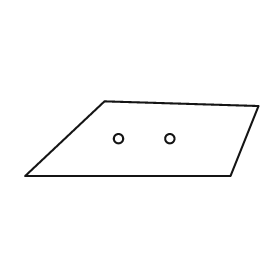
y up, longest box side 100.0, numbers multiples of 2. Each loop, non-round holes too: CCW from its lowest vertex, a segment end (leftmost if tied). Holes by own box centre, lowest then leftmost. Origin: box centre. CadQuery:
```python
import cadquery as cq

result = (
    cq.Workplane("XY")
    .moveTo(-50.0, -16.0)
    .lineTo(38.0, -16.0)
    .lineTo(50.0, 14.0)
    .lineTo(-16.0, 16.0)
    .close()
    .moveTo(-10.0, 0.0)
    .circle(2.0)
    .moveTo(12.0, 0.0)
    .circle(2.0)
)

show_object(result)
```